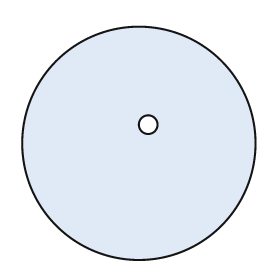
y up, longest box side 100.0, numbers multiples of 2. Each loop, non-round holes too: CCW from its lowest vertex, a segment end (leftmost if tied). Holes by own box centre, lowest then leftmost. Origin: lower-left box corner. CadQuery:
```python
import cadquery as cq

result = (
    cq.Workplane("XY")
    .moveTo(50.0, 50.0)
    .circle(50.0)
    .moveTo(54.0, 58.0)
    .circle(4.0)
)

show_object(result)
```